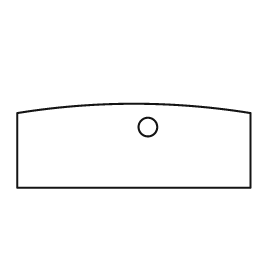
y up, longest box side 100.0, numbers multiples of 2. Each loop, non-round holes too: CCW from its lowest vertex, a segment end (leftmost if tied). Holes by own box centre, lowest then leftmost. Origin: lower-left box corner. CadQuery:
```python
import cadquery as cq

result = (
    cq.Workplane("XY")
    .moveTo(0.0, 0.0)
    .lineTo(100.0, 0.0)
    .lineTo(100.0, 32.0)
    .threePointArc((50.0, 36.0), (0.0, 32.0))
    .close()
    .moveTo(56.0, 26.0)
    .circle(4.0)
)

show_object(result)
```